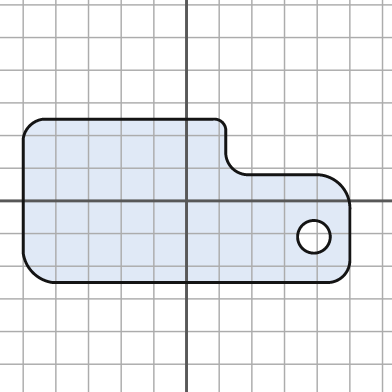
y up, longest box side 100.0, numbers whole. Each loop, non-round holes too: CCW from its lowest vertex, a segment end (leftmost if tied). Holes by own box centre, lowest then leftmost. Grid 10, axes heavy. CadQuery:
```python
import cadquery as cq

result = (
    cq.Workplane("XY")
    .moveTo(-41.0, -25.0)
    .lineTo(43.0, -25.0)
    .threePointArc((48.0, -23.0), (50.0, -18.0))
    .lineTo(50.0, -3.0)
    .threePointArc((47.0, 5.0), (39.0, 8.0))
    .lineTo(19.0, 8.0)
    .threePointArc((14.0, 10.0), (12.0, 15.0))
    .lineTo(12.0, 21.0)
    .threePointArc((11.0, 24.0), (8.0, 25.0))
    .lineTo(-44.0, 25.0)
    .threePointArc((-48.0, 23.0), (-50.0, 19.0))
    .lineTo(-50.0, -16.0)
    .threePointArc((-47.0, -22.0), (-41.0, -25.0))
    .close()
    .moveTo(39.0, -11.0)
    .circle(5.0)
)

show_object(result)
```